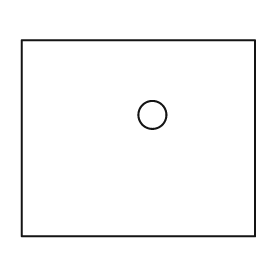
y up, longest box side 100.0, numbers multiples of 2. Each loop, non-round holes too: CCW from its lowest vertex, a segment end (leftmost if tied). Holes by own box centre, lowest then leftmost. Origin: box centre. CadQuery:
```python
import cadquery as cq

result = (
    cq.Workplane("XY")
    .moveTo(-50.0, -42.0)
    .lineTo(50.0, -42.0)
    .lineTo(50.0, 42.0)
    .lineTo(-50.0, 42.0)
    .close()
    .moveTo(6.0, 10.0)
    .circle(6.0)
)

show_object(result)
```